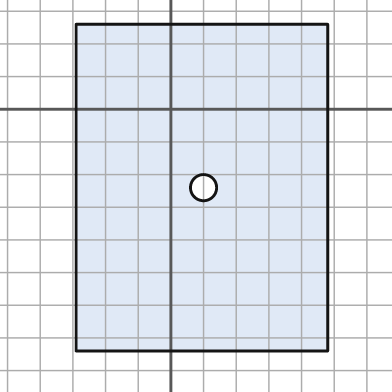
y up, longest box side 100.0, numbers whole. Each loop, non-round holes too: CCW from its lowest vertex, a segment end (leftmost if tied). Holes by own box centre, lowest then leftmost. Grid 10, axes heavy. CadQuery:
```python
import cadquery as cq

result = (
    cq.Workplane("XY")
    .moveTo(-29.0, -74.0)
    .lineTo(48.0, -74.0)
    .lineTo(48.0, 26.0)
    .lineTo(-29.0, 26.0)
    .close()
    .moveTo(10.0, -24.0)
    .circle(4.0)
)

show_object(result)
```